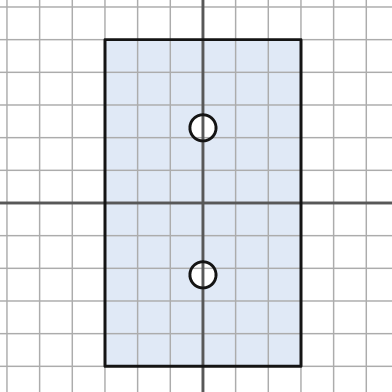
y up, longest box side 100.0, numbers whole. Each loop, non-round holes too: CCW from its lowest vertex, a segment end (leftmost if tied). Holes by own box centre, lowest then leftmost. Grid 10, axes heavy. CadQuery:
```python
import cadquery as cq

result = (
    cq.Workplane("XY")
    .moveTo(-30.0, -50.0)
    .lineTo(30.0, -50.0)
    .lineTo(30.0, 50.0)
    .lineTo(-30.0, 50.0)
    .close()
    .moveTo(0.0, -22.0)
    .circle(4.0)
    .moveTo(0.0, 23.0)
    .circle(4.0)
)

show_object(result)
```